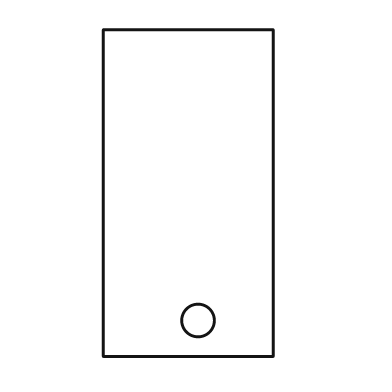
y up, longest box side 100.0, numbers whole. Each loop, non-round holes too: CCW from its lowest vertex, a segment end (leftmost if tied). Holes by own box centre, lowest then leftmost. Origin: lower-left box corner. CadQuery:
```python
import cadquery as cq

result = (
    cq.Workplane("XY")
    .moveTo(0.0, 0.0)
    .lineTo(52.0, 0.0)
    .lineTo(52.0, 100.0)
    .lineTo(0.0, 100.0)
    .close()
    .moveTo(29.0, 11.0)
    .circle(5.0)
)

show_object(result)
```